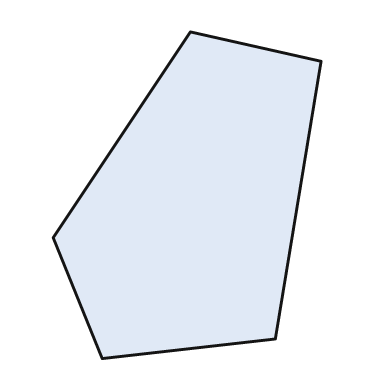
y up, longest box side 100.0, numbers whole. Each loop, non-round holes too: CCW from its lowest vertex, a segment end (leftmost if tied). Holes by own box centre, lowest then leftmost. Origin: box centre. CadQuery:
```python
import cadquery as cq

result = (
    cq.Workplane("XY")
    .moveTo(-26.0, -50.0)
    .lineTo(27.0, -44.0)
    .lineTo(41.0, 41.0)
    .lineTo(1.0, 50.0)
    .lineTo(-41.0, -13.0)
    .close()
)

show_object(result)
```